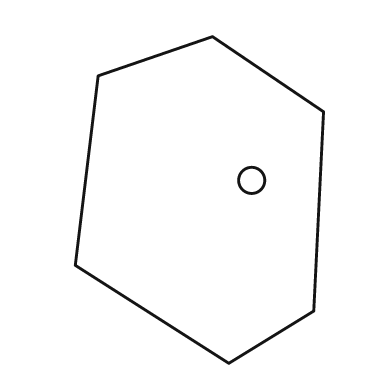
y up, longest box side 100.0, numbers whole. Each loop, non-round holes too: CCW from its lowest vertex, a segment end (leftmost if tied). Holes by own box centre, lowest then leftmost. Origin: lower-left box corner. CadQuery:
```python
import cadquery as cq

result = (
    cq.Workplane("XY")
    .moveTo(47.0, 0.0)
    .lineTo(73.0, 16.0)
    .lineTo(76.0, 77.0)
    .lineTo(42.0, 100.0)
    .lineTo(7.0, 88.0)
    .lineTo(0.0, 30.0)
    .close()
    .moveTo(54.0, 56.0)
    .circle(4.0)
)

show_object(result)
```